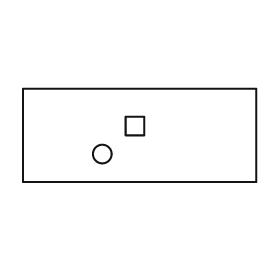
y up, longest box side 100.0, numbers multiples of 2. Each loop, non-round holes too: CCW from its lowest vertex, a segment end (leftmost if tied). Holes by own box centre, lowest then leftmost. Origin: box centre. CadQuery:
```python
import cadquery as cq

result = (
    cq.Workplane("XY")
    .moveTo(-50.0, -20.0)
    .lineTo(50.0, -20.0)
    .lineTo(50.0, 20.0)
    .lineTo(-50.0, 20.0)
    .close()
    .moveTo(-16.0, -8.0)
    .circle(4.0)
    .moveTo(-6.0, 0.0)
    .lineTo(2.0, 0.0)
    .lineTo(2.0, 8.0)
    .lineTo(-6.0, 8.0)
    .close()
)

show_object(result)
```